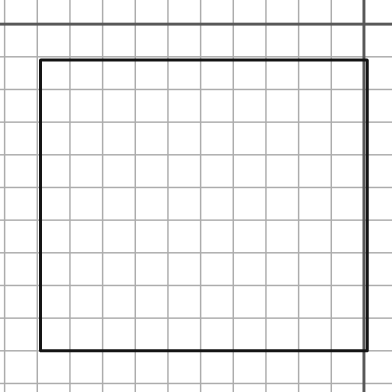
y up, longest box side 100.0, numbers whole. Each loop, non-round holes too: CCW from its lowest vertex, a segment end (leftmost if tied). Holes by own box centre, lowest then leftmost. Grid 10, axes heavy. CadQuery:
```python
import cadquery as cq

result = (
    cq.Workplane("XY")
    .moveTo(-99.0, -100.0)
    .lineTo(1.0, -100.0)
    .lineTo(1.0, -11.0)
    .lineTo(-99.0, -11.0)
    .close()
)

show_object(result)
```